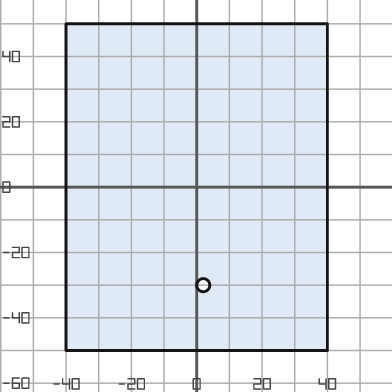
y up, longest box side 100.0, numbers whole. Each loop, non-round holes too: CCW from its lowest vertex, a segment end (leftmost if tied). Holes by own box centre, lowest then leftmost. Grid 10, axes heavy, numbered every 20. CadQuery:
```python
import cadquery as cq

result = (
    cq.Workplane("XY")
    .moveTo(-40.0, -50.0)
    .lineTo(40.0, -50.0)
    .lineTo(40.0, 50.0)
    .lineTo(-40.0, 50.0)
    .close()
    .moveTo(2.0, -30.0)
    .circle(2.0)
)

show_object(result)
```